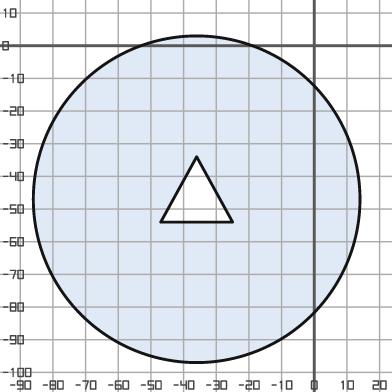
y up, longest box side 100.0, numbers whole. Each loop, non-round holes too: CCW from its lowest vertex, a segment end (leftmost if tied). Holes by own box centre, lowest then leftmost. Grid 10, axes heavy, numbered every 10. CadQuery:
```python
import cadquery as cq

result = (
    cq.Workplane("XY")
    .moveTo(-36.0, -47.0)
    .circle(50.0)
    .moveTo(-47.0, -54.0)
    .lineTo(-25.0, -54.0)
    .lineTo(-36.0, -34.0)
    .close()
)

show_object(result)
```